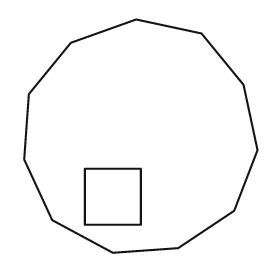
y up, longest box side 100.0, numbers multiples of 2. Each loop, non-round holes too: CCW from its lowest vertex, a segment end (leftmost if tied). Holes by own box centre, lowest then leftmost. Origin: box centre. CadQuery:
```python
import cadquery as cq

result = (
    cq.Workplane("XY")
    .moveTo(-12.0, -50.0)
    .lineTo(16.0, -48.0)
    .lineTo(40.0, -32.0)
    .lineTo(50.0, -6.0)
    .lineTo(44.0, 22.0)
    .lineTo(26.0, 44.0)
    .lineTo(-2.0, 50.0)
    .lineTo(-30.0, 40.0)
    .lineTo(-48.0, 18.0)
    .lineTo(-50.0, -10.0)
    .lineTo(-38.0, -36.0)
    .close()
    .moveTo(-24.0, -38.0)
    .lineTo(0.0, -38.0)
    .lineTo(0.0, -14.0)
    .lineTo(-24.0, -14.0)
    .close()
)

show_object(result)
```